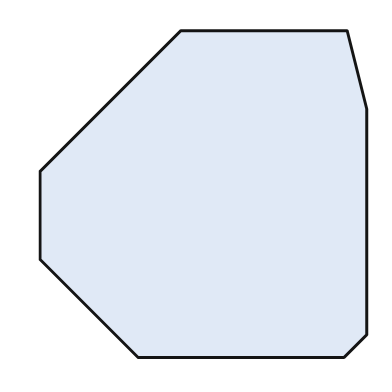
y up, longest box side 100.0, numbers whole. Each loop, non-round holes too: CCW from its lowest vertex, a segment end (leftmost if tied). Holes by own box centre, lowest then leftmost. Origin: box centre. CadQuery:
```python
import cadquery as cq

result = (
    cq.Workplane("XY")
    .moveTo(-20.0, -50.0)
    .lineTo(43.0, -50.0)
    .lineTo(50.0, -43.0)
    .lineTo(50.0, 26.0)
    .lineTo(44.0, 50.0)
    .lineTo(-7.0, 50.0)
    .lineTo(-50.0, 7.0)
    .lineTo(-50.0, -20.0)
    .close()
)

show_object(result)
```